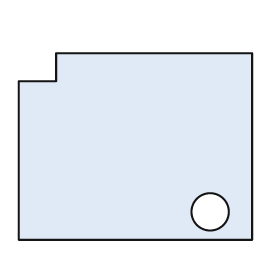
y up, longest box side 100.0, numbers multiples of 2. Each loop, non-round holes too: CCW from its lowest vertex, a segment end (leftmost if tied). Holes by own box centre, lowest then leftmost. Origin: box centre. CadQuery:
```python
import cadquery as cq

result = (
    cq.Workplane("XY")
    .moveTo(-50.0, -40.0)
    .lineTo(50.0, -40.0)
    .lineTo(50.0, 40.0)
    .lineTo(-34.0, 40.0)
    .lineTo(-34.0, 28.0)
    .lineTo(-50.0, 28.0)
    .close()
    .moveTo(32.0, -28.0)
    .circle(8.0)
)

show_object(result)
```